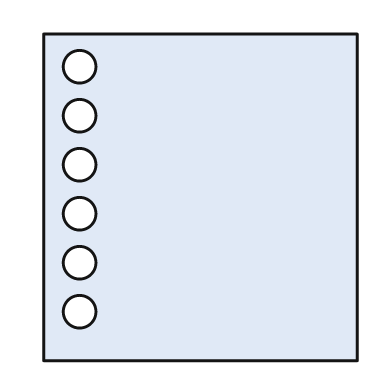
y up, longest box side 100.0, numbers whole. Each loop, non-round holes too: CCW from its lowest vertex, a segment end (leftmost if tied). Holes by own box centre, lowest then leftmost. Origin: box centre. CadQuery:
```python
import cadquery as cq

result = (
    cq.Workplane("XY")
    .moveTo(-48.0, -50.0)
    .lineTo(48.0, -50.0)
    .lineTo(48.0, 50.0)
    .lineTo(-48.0, 50.0)
    .close()
    .moveTo(-37.0, -35.0)
    .circle(5.0)
    .moveTo(-37.0, -20.0)
    .circle(5.0)
    .moveTo(-37.0, -5.0)
    .circle(5.0)
    .moveTo(-37.0, 10.0)
    .circle(5.0)
    .moveTo(-37.0, 25.0)
    .circle(5.0)
    .moveTo(-37.0, 40.0)
    .circle(5.0)
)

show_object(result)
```